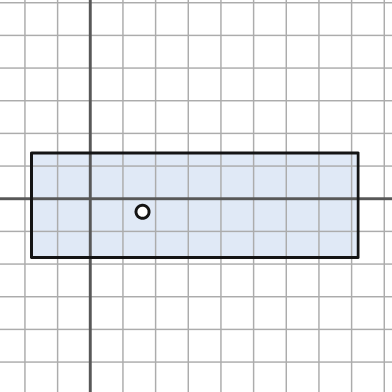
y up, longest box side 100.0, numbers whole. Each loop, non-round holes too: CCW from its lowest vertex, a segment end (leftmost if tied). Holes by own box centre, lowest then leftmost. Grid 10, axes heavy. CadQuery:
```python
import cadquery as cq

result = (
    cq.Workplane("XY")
    .moveTo(-18.0, -18.0)
    .lineTo(82.0, -18.0)
    .lineTo(82.0, 14.0)
    .lineTo(-18.0, 14.0)
    .close()
    .moveTo(16.0, -4.0)
    .circle(2.0)
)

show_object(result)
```